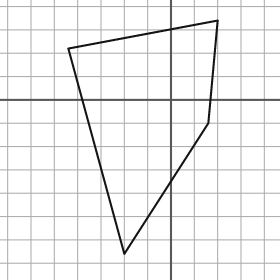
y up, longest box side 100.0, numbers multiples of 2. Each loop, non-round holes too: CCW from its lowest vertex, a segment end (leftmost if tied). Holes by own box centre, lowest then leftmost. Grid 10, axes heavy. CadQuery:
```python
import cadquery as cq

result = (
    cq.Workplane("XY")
    .moveTo(-20.0, -66.0)
    .lineTo(16.0, -10.0)
    .lineTo(20.0, 34.0)
    .lineTo(-44.0, 22.0)
    .close()
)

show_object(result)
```